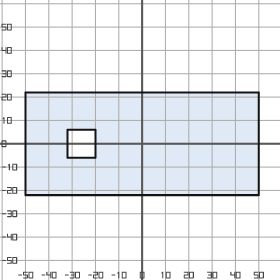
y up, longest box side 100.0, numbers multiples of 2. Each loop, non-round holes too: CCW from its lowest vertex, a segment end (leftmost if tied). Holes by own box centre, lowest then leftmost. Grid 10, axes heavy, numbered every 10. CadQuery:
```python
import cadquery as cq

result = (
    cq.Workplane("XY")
    .moveTo(-50.0, -22.0)
    .lineTo(50.0, -22.0)
    .lineTo(50.0, 22.0)
    .lineTo(-50.0, 22.0)
    .close()
    .moveTo(-32.0, -6.0)
    .lineTo(-20.0, -6.0)
    .lineTo(-20.0, 6.0)
    .lineTo(-32.0, 6.0)
    .close()
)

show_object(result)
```